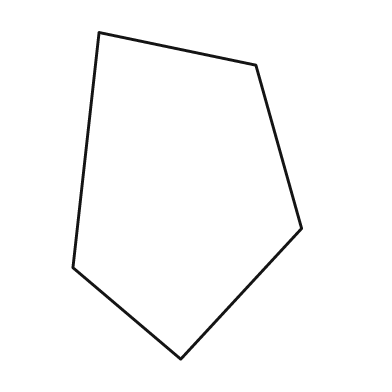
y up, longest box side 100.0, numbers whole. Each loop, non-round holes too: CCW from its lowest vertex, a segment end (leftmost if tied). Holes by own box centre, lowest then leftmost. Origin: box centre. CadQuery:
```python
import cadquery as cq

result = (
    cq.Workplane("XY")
    .moveTo(-2.0, -50.0)
    .lineTo(35.0, -10.0)
    .lineTo(21.0, 40.0)
    .lineTo(-27.0, 50.0)
    .lineTo(-35.0, -22.0)
    .close()
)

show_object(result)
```